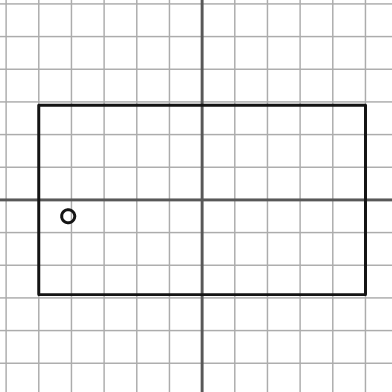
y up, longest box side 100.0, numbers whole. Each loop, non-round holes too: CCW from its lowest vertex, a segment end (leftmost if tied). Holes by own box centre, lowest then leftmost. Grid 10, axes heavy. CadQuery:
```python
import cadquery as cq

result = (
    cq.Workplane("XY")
    .moveTo(-50.0, -29.0)
    .lineTo(50.0, -29.0)
    .lineTo(50.0, 29.0)
    .lineTo(-50.0, 29.0)
    .close()
    .moveTo(-41.0, -5.0)
    .circle(2.0)
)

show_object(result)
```